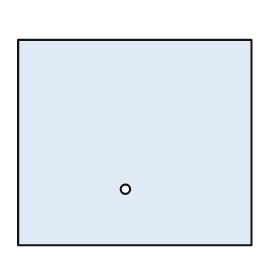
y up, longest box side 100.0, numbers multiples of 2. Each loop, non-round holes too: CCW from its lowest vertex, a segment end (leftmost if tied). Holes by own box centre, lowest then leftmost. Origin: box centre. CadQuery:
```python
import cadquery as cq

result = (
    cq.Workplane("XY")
    .moveTo(-50.0, -44.0)
    .lineTo(50.0, -44.0)
    .lineTo(50.0, 44.0)
    .lineTo(-50.0, 44.0)
    .close()
    .moveTo(-4.0, -20.0)
    .circle(2.0)
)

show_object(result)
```